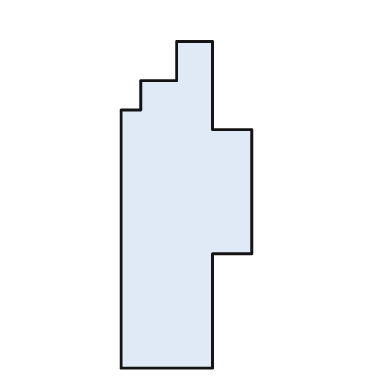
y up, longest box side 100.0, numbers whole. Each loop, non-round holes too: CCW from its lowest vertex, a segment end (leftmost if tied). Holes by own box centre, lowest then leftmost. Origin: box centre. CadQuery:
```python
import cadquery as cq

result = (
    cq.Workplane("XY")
    .moveTo(-20.0, -50.0)
    .lineTo(8.0, -50.0)
    .lineTo(8.0, -15.0)
    .lineTo(20.0, -15.0)
    .lineTo(20.0, 23.0)
    .lineTo(8.0, 23.0)
    .lineTo(8.0, 50.0)
    .lineTo(-3.0, 50.0)
    .lineTo(-3.0, 38.0)
    .lineTo(-14.0, 38.0)
    .lineTo(-14.0, 29.0)
    .lineTo(-20.0, 29.0)
    .close()
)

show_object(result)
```